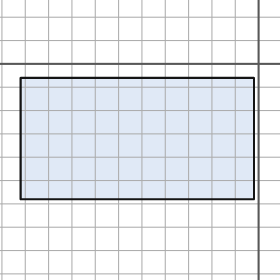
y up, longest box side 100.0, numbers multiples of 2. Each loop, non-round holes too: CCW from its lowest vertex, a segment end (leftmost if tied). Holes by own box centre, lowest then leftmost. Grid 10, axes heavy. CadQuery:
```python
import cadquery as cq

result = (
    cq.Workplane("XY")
    .moveTo(-102.0, -58.0)
    .lineTo(-2.0, -58.0)
    .lineTo(-2.0, -6.0)
    .lineTo(-102.0, -6.0)
    .close()
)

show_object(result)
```